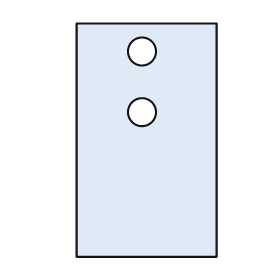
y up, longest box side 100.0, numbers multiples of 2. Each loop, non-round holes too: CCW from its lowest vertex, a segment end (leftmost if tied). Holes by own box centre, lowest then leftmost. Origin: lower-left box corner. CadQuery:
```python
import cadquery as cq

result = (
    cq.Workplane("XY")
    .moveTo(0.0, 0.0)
    .lineTo(60.0, 0.0)
    .lineTo(60.0, 100.0)
    .lineTo(0.0, 100.0)
    .close()
    .moveTo(28.0, 62.0)
    .circle(6.0)
    .moveTo(28.0, 88.0)
    .circle(6.0)
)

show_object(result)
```